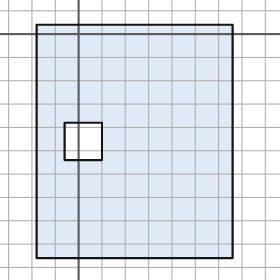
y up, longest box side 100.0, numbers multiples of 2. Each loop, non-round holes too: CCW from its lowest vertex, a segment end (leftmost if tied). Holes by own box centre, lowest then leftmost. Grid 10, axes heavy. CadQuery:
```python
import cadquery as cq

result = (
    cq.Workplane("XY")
    .moveTo(-18.0, -96.0)
    .lineTo(66.0, -96.0)
    .lineTo(66.0, 4.0)
    .lineTo(-18.0, 4.0)
    .close()
    .moveTo(-6.0, -54.0)
    .lineTo(10.0, -54.0)
    .lineTo(10.0, -38.0)
    .lineTo(-6.0, -38.0)
    .close()
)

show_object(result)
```